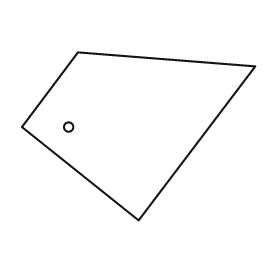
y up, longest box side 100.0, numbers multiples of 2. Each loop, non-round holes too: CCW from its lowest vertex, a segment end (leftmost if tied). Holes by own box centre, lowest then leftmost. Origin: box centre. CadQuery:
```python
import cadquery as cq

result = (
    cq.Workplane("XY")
    .moveTo(0.0, -36.0)
    .lineTo(50.0, 30.0)
    .lineTo(-26.0, 36.0)
    .lineTo(-50.0, 4.0)
    .close()
    .moveTo(-30.0, 4.0)
    .circle(2.0)
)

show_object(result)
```